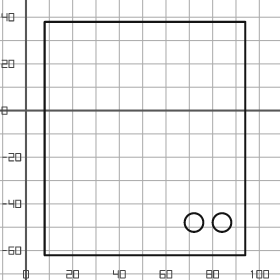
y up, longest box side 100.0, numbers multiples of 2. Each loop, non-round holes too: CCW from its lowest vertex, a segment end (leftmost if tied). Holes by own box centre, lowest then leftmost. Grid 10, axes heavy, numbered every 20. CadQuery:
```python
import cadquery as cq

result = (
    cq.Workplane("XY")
    .moveTo(8.0, -62.0)
    .lineTo(94.0, -62.0)
    .lineTo(94.0, 38.0)
    .lineTo(8.0, 38.0)
    .close()
    .moveTo(72.0, -48.0)
    .circle(4.0)
    .moveTo(84.0, -48.0)
    .circle(4.0)
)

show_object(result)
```